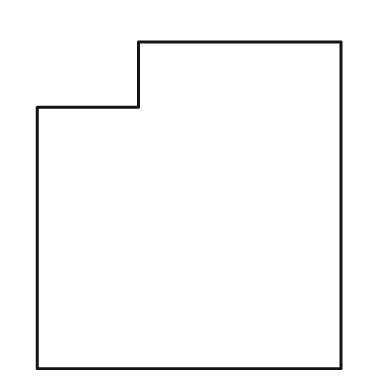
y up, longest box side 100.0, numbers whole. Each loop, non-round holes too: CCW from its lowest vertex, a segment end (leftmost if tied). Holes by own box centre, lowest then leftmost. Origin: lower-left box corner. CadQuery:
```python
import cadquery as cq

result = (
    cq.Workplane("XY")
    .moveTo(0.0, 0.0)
    .lineTo(93.0, 0.0)
    .lineTo(93.0, 100.0)
    .lineTo(31.0, 100.0)
    .lineTo(31.0, 80.0)
    .lineTo(0.0, 80.0)
    .close()
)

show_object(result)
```